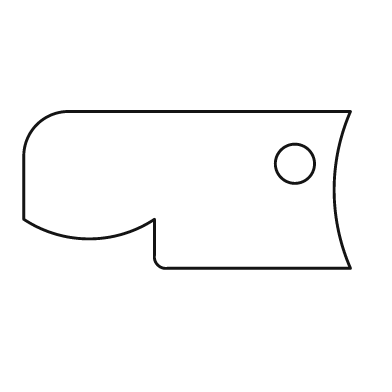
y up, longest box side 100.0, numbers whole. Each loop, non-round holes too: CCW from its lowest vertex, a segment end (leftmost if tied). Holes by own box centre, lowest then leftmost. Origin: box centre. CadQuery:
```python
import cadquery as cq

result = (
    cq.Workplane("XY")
    .moveTo(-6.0, -24.0)
    .lineTo(50.0, -24.0)
    .threePointArc((45.0, 0.0), (50.0, 24.0))
    .lineTo(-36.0, 24.0)
    .threePointArc((-46.0, 20.0), (-50.0, 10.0))
    .lineTo(-50.0, -9.0)
    .threePointArc((-30.0, -15.0), (-10.0, -9.0))
    .lineTo(-10.0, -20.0)
    .threePointArc((-9.0, -23.0), (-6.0, -24.0))
    .close()
    .moveTo(33.0, 8.0)
    .circle(6.0)
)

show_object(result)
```